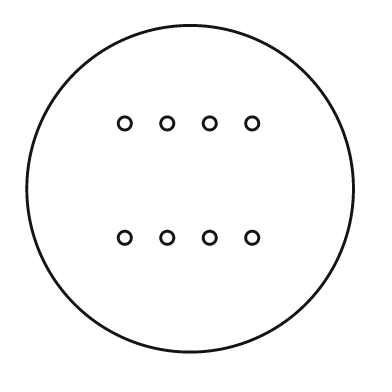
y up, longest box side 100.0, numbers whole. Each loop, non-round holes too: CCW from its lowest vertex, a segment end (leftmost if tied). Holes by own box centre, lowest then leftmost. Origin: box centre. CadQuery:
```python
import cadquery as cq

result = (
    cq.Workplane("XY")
    .moveTo(0.0, 0.0)
    .circle(50.0)
    .moveTo(-20.0, -15.0)
    .circle(2.0)
    .moveTo(-7.0, -15.0)
    .circle(2.0)
    .moveTo(6.0, -15.0)
    .circle(2.0)
    .moveTo(19.0, -15.0)
    .circle(2.0)
    .moveTo(-20.0, 20.0)
    .circle(2.0)
    .moveTo(-7.0, 20.0)
    .circle(2.0)
    .moveTo(6.0, 20.0)
    .circle(2.0)
    .moveTo(19.0, 20.0)
    .circle(2.0)
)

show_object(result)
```